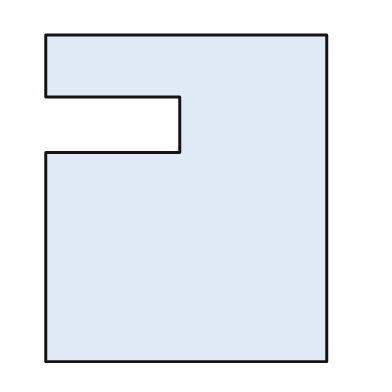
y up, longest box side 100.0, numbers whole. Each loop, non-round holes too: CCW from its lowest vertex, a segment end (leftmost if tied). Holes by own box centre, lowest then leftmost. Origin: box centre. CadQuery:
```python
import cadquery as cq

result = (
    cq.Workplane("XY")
    .moveTo(-43.0, -50.0)
    .lineTo(43.0, -50.0)
    .lineTo(43.0, 50.0)
    .lineTo(-43.0, 50.0)
    .lineTo(-43.0, 31.0)
    .lineTo(-2.0, 31.0)
    .lineTo(-2.0, 14.0)
    .lineTo(-43.0, 14.0)
    .close()
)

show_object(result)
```